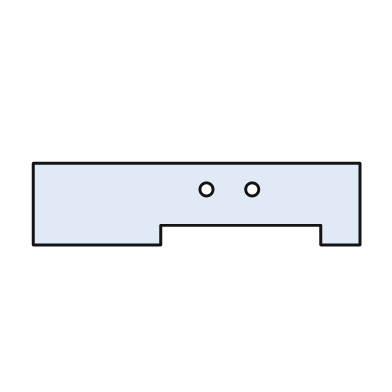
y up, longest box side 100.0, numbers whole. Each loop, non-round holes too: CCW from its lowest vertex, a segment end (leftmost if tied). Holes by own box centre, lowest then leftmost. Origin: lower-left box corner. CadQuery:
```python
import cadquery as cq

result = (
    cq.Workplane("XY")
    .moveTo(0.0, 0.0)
    .lineTo(39.0, 0.0)
    .lineTo(39.0, 6.0)
    .lineTo(88.0, 6.0)
    .lineTo(88.0, 0.0)
    .lineTo(100.0, 0.0)
    .lineTo(100.0, 25.0)
    .lineTo(0.0, 25.0)
    .close()
    .moveTo(53.0, 17.0)
    .circle(2.0)
    .moveTo(67.0, 17.0)
    .circle(2.0)
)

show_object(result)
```